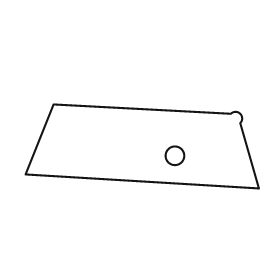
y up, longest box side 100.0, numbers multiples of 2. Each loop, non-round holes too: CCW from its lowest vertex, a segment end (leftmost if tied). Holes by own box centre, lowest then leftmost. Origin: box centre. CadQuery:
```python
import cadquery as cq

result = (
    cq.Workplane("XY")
    .moveTo(50.0, -18.0)
    .lineTo(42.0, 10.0)
    .threePointArc((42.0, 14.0), (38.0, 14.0))
    .lineTo(-38.0, 18.0)
    .lineTo(-50.0, -12.0)
    .close()
    .moveTo(14.0, -4.0)
    .circle(4.0)
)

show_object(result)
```